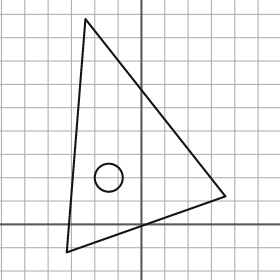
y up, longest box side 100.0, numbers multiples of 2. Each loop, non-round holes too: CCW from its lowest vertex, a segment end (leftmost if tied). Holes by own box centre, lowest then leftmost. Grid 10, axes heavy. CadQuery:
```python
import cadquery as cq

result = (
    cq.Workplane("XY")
    .moveTo(-32.0, -12.0)
    .lineTo(36.0, 12.0)
    .lineTo(-24.0, 88.0)
    .close()
    .moveTo(-14.0, 20.0)
    .circle(6.0)
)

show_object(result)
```